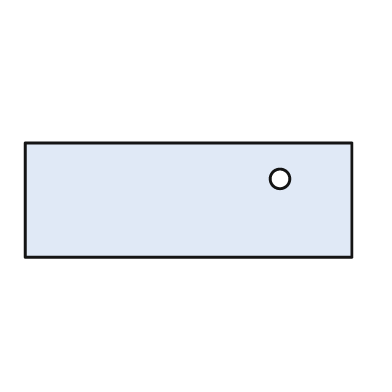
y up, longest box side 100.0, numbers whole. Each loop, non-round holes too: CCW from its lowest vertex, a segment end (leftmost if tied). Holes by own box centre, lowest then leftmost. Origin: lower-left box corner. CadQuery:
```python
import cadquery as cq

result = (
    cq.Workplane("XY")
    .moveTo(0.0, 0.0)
    .lineTo(100.0, 0.0)
    .lineTo(100.0, 35.0)
    .lineTo(0.0, 35.0)
    .close()
    .moveTo(78.0, 24.0)
    .circle(3.0)
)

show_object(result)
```